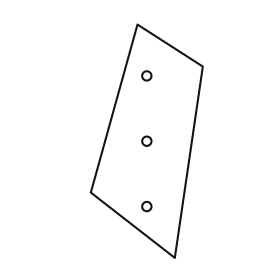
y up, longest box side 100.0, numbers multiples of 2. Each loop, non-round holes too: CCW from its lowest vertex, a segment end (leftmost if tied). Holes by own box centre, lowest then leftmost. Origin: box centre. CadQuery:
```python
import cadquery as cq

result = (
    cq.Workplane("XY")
    .moveTo(12.0, -50.0)
    .lineTo(24.0, 32.0)
    .lineTo(-4.0, 50.0)
    .lineTo(-24.0, -22.0)
    .close()
    .moveTo(0.0, -28.0)
    .circle(2.0)
    .moveTo(0.0, 0.0)
    .circle(2.0)
    .moveTo(0.0, 28.0)
    .circle(2.0)
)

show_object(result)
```